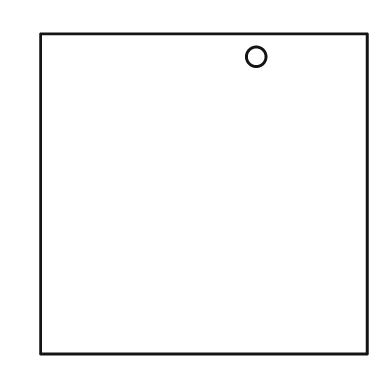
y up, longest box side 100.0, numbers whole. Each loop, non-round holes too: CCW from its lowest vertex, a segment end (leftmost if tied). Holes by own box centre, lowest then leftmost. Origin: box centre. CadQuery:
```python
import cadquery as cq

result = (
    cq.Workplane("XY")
    .moveTo(-50.0, -49.0)
    .lineTo(50.0, -49.0)
    .lineTo(50.0, 49.0)
    .lineTo(-50.0, 49.0)
    .close()
    .moveTo(16.0, 42.0)
    .circle(3.0)
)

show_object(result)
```